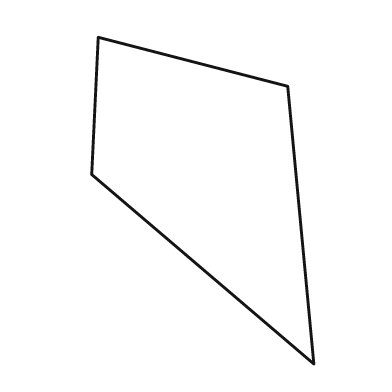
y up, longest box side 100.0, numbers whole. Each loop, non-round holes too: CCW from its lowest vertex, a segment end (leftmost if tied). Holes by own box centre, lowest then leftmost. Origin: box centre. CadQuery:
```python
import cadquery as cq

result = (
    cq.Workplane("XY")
    .moveTo(34.0, -50.0)
    .lineTo(26.0, 35.0)
    .lineTo(-32.0, 50.0)
    .lineTo(-34.0, 8.0)
    .close()
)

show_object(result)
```